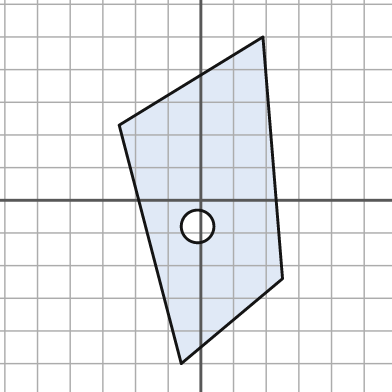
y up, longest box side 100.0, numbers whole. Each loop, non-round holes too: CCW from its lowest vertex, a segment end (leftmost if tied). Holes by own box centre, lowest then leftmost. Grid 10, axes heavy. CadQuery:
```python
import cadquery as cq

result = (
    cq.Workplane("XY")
    .moveTo(-6.0, -50.0)
    .lineTo(25.0, -24.0)
    .lineTo(19.0, 50.0)
    .lineTo(-25.0, 23.0)
    .close()
    .moveTo(-1.0, -8.0)
    .circle(5.0)
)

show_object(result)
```